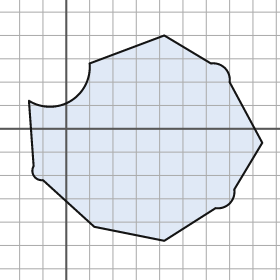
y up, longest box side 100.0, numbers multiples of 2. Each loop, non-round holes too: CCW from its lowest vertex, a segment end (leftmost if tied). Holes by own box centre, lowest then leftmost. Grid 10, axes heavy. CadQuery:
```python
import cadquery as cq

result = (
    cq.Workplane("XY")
    .moveTo(42.0, -48.0)
    .lineTo(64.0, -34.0)
    .threePointArc((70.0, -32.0), (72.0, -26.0))
    .lineTo(84.0, -6.0)
    .lineTo(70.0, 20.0)
    .threePointArc((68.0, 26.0), (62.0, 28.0))
    .lineTo(42.0, 40.0)
    .lineTo(10.0, 28.0)
    .threePointArc((2.0, 12.0), (-16.0, 12.0))
    .lineTo(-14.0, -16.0)
    .threePointArc((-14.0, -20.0), (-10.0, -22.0))
    .lineTo(12.0, -42.0)
    .close()
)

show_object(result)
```